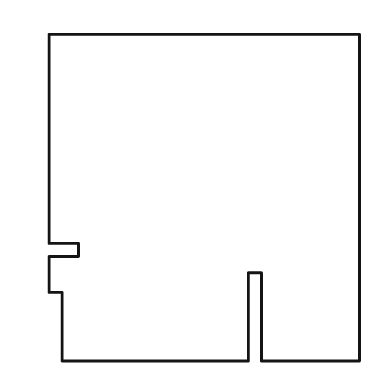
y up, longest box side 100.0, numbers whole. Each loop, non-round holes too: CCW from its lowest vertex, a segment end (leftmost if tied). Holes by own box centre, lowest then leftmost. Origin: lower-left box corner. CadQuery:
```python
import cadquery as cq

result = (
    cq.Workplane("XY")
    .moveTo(4.0, 0.0)
    .lineTo(61.0, 0.0)
    .lineTo(61.0, 27.0)
    .lineTo(65.0, 27.0)
    .lineTo(65.0, 0.0)
    .lineTo(95.0, 0.0)
    .lineTo(95.0, 100.0)
    .lineTo(0.0, 100.0)
    .lineTo(0.0, 36.0)
    .lineTo(9.0, 36.0)
    .lineTo(9.0, 32.0)
    .lineTo(0.0, 32.0)
    .lineTo(0.0, 21.0)
    .lineTo(4.0, 21.0)
    .close()
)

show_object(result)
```